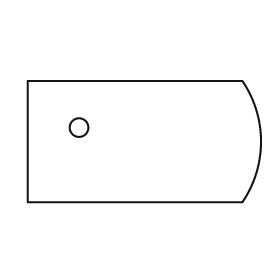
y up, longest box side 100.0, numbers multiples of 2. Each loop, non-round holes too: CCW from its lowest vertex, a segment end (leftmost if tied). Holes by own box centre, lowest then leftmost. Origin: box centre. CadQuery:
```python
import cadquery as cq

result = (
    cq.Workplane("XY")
    .moveTo(-50.0, -26.0)
    .lineTo(42.0, -26.0)
    .threePointArc((50.0, 0.0), (42.0, 26.0))
    .lineTo(-50.0, 26.0)
    .close()
    .moveTo(-28.0, 6.0)
    .circle(4.0)
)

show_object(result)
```